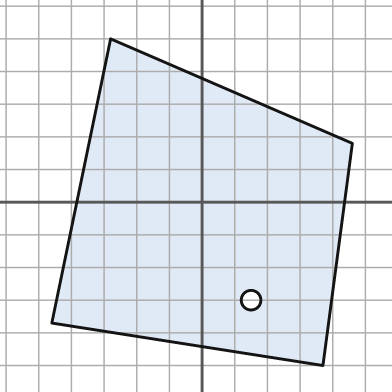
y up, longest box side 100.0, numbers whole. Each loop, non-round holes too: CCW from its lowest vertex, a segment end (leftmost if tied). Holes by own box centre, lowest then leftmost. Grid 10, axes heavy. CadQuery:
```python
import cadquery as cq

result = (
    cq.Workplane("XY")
    .moveTo(37.0, -50.0)
    .lineTo(46.0, 18.0)
    .lineTo(-28.0, 50.0)
    .lineTo(-46.0, -37.0)
    .close()
    .moveTo(15.0, -30.0)
    .circle(3.0)
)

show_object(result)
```